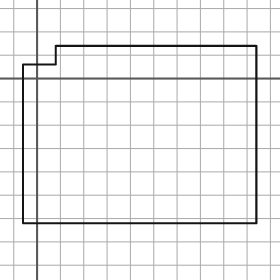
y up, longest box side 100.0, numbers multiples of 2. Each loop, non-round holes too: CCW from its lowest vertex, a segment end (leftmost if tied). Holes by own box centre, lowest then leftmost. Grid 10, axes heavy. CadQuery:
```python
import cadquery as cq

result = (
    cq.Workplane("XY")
    .moveTo(-6.0, -62.0)
    .lineTo(94.0, -62.0)
    .lineTo(94.0, 14.0)
    .lineTo(8.0, 14.0)
    .lineTo(8.0, 6.0)
    .lineTo(-6.0, 6.0)
    .close()
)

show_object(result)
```